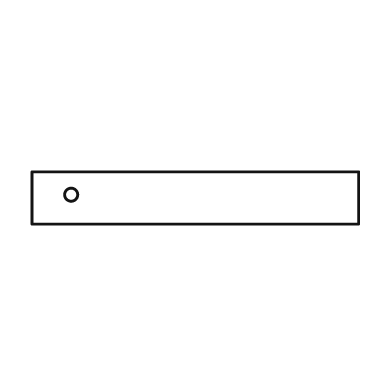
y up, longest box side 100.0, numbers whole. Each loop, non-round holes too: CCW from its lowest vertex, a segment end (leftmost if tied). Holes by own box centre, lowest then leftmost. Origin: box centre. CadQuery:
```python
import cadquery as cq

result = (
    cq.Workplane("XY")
    .moveTo(-50.0, -8.0)
    .lineTo(50.0, -8.0)
    .lineTo(50.0, 8.0)
    .lineTo(-50.0, 8.0)
    .close()
    .moveTo(-38.0, 1.0)
    .circle(2.0)
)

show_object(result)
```